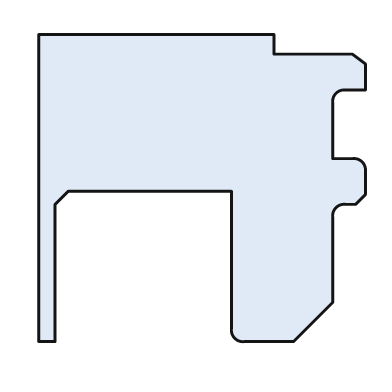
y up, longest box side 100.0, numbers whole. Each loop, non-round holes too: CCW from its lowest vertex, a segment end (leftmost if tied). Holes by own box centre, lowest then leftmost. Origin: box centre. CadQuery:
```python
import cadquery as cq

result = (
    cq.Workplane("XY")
    .moveTo(-50.0, -47.0)
    .lineTo(-45.0, -47.0)
    .lineTo(-45.0, -5.0)
    .lineTo(-41.0, -1.0)
    .lineTo(9.0, -1.0)
    .lineTo(9.0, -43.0)
    .threePointArc((10.0, -46.0), (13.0, -47.0))
    .lineTo(28.0, -47.0)
    .lineTo(40.0, -35.0)
    .lineTo(40.0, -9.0)
    .threePointArc((41.0, -6.0), (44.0, -5.0))
    .lineTo(47.0, -5.0)
    .lineTo(50.0, -2.0)
    .lineTo(50.0, 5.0)
    .threePointArc((49.0, 8.0), (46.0, 9.0))
    .lineTo(40.0, 9.0)
    .lineTo(40.0, 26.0)
    .threePointArc((41.0, 29.0), (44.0, 30.0))
    .lineTo(50.0, 30.0)
    .lineTo(50.0, 38.0)
    .lineTo(46.0, 41.0)
    .lineTo(22.0, 41.0)
    .lineTo(22.0, 47.0)
    .lineTo(-50.0, 47.0)
    .close()
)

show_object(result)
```